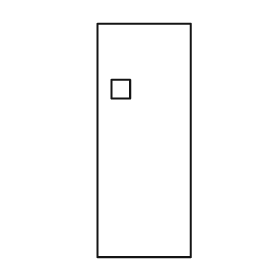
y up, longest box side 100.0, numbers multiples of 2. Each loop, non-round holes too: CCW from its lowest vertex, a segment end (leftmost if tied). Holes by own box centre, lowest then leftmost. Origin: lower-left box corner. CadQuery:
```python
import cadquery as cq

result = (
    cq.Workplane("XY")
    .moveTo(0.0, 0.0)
    .lineTo(40.0, 0.0)
    .lineTo(40.0, 100.0)
    .lineTo(0.0, 100.0)
    .close()
    .moveTo(6.0, 68.0)
    .lineTo(14.0, 68.0)
    .lineTo(14.0, 76.0)
    .lineTo(6.0, 76.0)
    .close()
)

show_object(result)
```